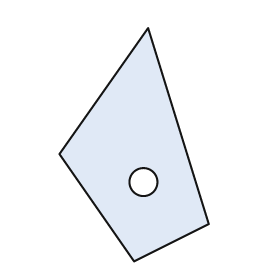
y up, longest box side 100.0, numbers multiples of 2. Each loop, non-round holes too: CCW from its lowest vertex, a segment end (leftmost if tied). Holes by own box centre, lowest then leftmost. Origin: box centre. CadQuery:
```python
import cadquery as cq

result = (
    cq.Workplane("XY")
    .moveTo(0.0, -50.0)
    .lineTo(32.0, -34.0)
    .lineTo(6.0, 50.0)
    .lineTo(-32.0, -4.0)
    .close()
    .moveTo(4.0, -16.0)
    .circle(6.0)
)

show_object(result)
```